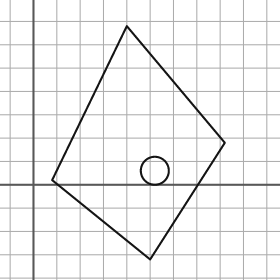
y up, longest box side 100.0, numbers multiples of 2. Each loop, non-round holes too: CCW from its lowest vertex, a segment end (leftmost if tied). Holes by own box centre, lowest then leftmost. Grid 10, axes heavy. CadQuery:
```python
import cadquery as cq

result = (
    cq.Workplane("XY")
    .moveTo(50.0, -32.0)
    .lineTo(82.0, 18.0)
    .lineTo(40.0, 68.0)
    .lineTo(8.0, 2.0)
    .close()
    .moveTo(52.0, 6.0)
    .circle(6.0)
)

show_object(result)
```